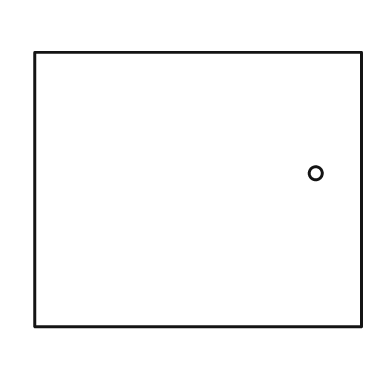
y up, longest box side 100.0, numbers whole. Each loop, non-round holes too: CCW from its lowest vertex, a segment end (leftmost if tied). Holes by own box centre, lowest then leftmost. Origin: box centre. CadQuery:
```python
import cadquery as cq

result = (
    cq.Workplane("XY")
    .moveTo(-50.0, -42.0)
    .lineTo(50.0, -42.0)
    .lineTo(50.0, 42.0)
    .lineTo(-50.0, 42.0)
    .close()
    .moveTo(36.0, 5.0)
    .circle(2.0)
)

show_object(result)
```